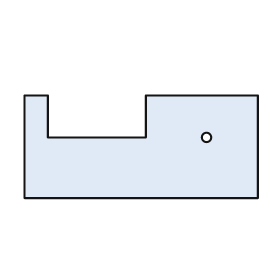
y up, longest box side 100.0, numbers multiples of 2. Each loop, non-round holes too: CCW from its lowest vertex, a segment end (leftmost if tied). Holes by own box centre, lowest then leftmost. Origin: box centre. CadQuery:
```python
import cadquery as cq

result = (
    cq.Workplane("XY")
    .moveTo(-50.0, -22.0)
    .lineTo(50.0, -22.0)
    .lineTo(50.0, 22.0)
    .lineTo(2.0, 22.0)
    .lineTo(2.0, 4.0)
    .lineTo(-40.0, 4.0)
    .lineTo(-40.0, 22.0)
    .lineTo(-50.0, 22.0)
    .close()
    .moveTo(28.0, 4.0)
    .circle(2.0)
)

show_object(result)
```